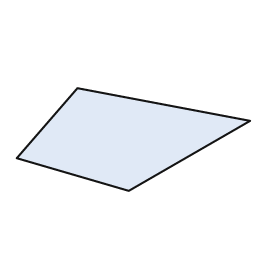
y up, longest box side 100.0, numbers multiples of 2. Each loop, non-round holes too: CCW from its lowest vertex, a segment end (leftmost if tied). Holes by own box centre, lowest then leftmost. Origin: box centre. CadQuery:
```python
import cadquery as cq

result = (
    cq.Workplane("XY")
    .moveTo(-2.0, -22.0)
    .lineTo(50.0, 8.0)
    .lineTo(-24.0, 22.0)
    .lineTo(-50.0, -8.0)
    .close()
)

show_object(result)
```